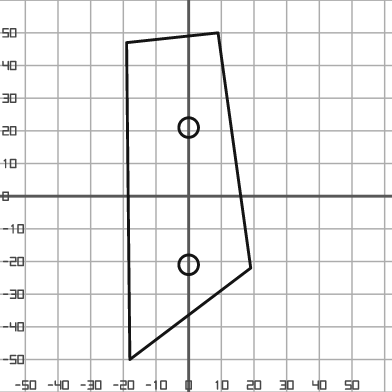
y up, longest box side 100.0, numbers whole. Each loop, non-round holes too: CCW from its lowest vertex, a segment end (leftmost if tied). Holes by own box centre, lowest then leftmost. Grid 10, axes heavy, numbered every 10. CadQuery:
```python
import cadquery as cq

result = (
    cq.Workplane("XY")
    .moveTo(-18.0, -50.0)
    .lineTo(19.0, -22.0)
    .lineTo(9.0, 50.0)
    .lineTo(-19.0, 47.0)
    .close()
    .moveTo(0.0, -21.0)
    .circle(3.0)
    .moveTo(0.0, 21.0)
    .circle(3.0)
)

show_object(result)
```